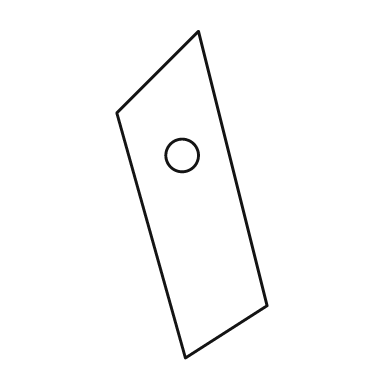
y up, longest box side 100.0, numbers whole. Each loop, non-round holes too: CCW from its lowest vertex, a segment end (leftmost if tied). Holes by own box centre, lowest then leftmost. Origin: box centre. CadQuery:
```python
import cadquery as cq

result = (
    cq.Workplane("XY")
    .moveTo(-2.0, -50.0)
    .lineTo(23.0, -34.0)
    .lineTo(2.0, 50.0)
    .lineTo(-23.0, 25.0)
    .close()
    .moveTo(-3.0, 12.0)
    .circle(5.0)
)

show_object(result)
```